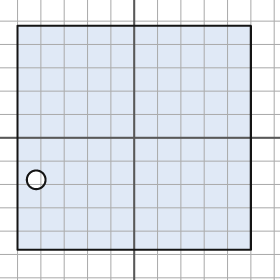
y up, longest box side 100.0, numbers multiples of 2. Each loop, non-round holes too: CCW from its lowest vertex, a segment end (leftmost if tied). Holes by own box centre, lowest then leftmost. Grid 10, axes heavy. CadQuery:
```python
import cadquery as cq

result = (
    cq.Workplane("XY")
    .moveTo(-50.0, -48.0)
    .lineTo(50.0, -48.0)
    .lineTo(50.0, 48.0)
    .lineTo(-50.0, 48.0)
    .close()
    .moveTo(-42.0, -18.0)
    .circle(4.0)
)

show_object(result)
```